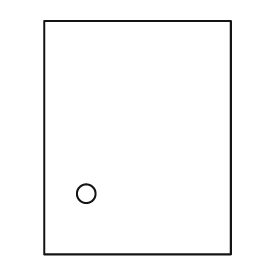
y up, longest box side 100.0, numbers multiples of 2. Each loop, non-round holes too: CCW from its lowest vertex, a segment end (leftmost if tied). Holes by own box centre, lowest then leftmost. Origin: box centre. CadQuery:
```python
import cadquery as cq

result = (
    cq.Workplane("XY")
    .moveTo(-40.0, -50.0)
    .lineTo(40.0, -50.0)
    .lineTo(40.0, 50.0)
    .lineTo(-40.0, 50.0)
    .close()
    .moveTo(-22.0, -24.0)
    .circle(4.0)
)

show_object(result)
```